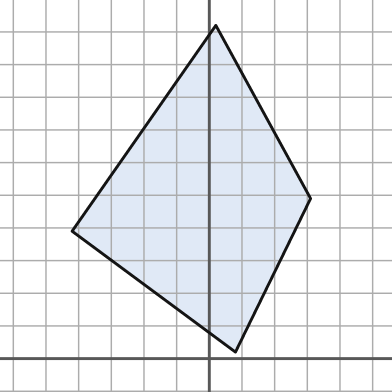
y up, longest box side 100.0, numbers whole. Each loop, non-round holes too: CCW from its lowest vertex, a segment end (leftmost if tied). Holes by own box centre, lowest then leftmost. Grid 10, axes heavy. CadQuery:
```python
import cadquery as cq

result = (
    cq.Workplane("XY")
    .moveTo(8.0, 2.0)
    .lineTo(31.0, 49.0)
    .lineTo(2.0, 102.0)
    .lineTo(-42.0, 39.0)
    .close()
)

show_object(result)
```